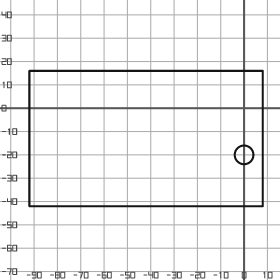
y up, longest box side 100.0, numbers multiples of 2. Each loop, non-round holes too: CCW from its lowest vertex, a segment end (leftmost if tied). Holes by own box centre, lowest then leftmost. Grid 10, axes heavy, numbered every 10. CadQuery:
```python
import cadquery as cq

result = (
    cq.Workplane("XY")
    .moveTo(-92.0, -42.0)
    .lineTo(8.0, -42.0)
    .lineTo(8.0, 16.0)
    .lineTo(-92.0, 16.0)
    .close()
    .moveTo(0.0, -20.0)
    .circle(4.0)
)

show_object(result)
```